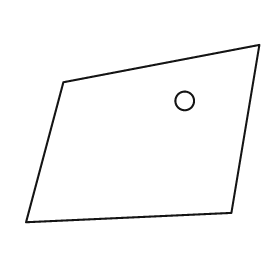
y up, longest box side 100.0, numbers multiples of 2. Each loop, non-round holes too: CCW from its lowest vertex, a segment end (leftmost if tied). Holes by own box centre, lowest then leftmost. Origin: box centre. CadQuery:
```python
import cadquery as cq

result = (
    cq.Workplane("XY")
    .moveTo(-50.0, -38.0)
    .lineTo(38.0, -34.0)
    .lineTo(50.0, 38.0)
    .lineTo(-34.0, 22.0)
    .close()
    .moveTo(18.0, 14.0)
    .circle(4.0)
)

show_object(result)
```